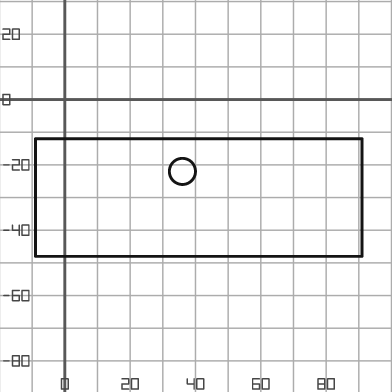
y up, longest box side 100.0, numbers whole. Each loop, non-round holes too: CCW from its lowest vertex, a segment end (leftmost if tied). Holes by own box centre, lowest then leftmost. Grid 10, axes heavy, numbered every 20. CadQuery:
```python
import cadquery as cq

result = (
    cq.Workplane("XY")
    .moveTo(-9.0, -48.0)
    .lineTo(91.0, -48.0)
    .lineTo(91.0, -12.0)
    .lineTo(-9.0, -12.0)
    .close()
    .moveTo(36.0, -22.0)
    .circle(4.0)
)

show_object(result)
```